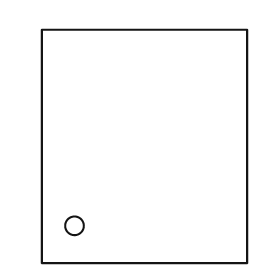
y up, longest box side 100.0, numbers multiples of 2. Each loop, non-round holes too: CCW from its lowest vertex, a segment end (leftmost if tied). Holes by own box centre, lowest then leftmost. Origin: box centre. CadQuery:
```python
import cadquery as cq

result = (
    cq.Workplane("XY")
    .moveTo(-44.0, -50.0)
    .lineTo(44.0, -50.0)
    .lineTo(44.0, 50.0)
    .lineTo(-44.0, 50.0)
    .close()
    .moveTo(-30.0, -34.0)
    .circle(4.0)
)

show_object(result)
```